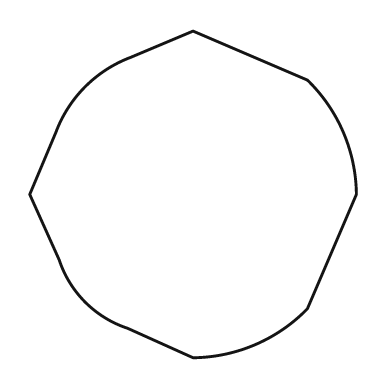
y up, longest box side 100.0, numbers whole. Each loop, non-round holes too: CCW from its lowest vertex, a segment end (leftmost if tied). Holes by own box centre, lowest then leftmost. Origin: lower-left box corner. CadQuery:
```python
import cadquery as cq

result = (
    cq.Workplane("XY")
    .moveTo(50.0, 0.0)
    .threePointArc((69.0, 4.0), (85.0, 15.0))
    .lineTo(100.0, 50.0)
    .threePointArc((96.0, 69.0), (85.0, 85.0))
    .lineTo(50.0, 100.0)
    .lineTo(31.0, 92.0)
    .threePointArc((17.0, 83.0), (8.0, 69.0))
    .lineTo(0.0, 50.0)
    .lineTo(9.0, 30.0)
    .threePointArc((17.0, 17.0), (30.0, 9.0))
    .close()
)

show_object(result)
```